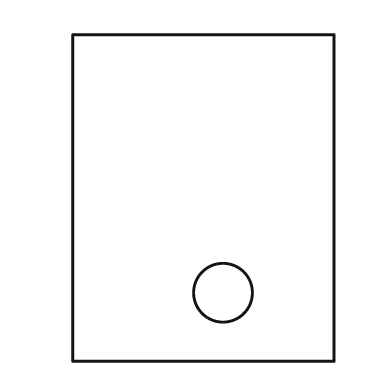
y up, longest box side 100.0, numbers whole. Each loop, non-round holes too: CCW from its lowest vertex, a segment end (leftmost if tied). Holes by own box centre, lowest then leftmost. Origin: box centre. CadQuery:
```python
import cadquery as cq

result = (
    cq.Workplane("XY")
    .moveTo(-40.0, -50.0)
    .lineTo(40.0, -50.0)
    .lineTo(40.0, 50.0)
    .lineTo(-40.0, 50.0)
    .close()
    .moveTo(6.0, -29.0)
    .circle(9.0)
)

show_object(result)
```